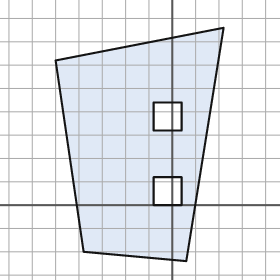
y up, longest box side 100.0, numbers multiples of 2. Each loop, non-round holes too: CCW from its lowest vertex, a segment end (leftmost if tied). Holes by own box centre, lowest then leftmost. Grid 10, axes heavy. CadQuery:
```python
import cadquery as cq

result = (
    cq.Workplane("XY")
    .moveTo(6.0, -24.0)
    .lineTo(22.0, 76.0)
    .lineTo(-50.0, 62.0)
    .lineTo(-38.0, -20.0)
    .close()
    .moveTo(-8.0, 0.0)
    .lineTo(4.0, 0.0)
    .lineTo(4.0, 12.0)
    .lineTo(-8.0, 12.0)
    .close()
    .moveTo(-8.0, 32.0)
    .lineTo(4.0, 32.0)
    .lineTo(4.0, 44.0)
    .lineTo(-8.0, 44.0)
    .close()
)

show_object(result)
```